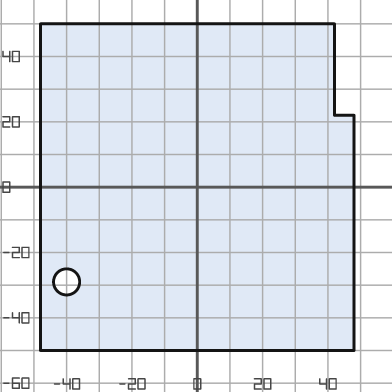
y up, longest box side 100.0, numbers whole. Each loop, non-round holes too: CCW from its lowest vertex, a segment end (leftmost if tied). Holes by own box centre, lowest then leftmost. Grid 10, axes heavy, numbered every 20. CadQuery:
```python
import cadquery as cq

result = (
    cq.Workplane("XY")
    .moveTo(-48.0, -50.0)
    .lineTo(48.0, -50.0)
    .lineTo(48.0, 22.0)
    .lineTo(42.0, 22.0)
    .lineTo(42.0, 50.0)
    .lineTo(-48.0, 50.0)
    .close()
    .moveTo(-40.0, -29.0)
    .circle(4.0)
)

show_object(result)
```